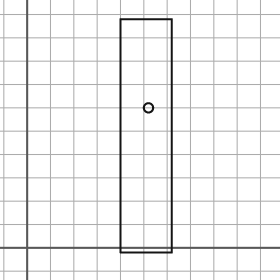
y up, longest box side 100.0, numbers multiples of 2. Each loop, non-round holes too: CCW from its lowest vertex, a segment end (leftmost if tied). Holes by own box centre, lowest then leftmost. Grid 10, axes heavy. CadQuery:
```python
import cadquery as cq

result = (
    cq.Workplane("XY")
    .moveTo(40.0, -2.0)
    .lineTo(62.0, -2.0)
    .lineTo(62.0, 98.0)
    .lineTo(40.0, 98.0)
    .close()
    .moveTo(52.0, 60.0)
    .circle(2.0)
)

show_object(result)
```